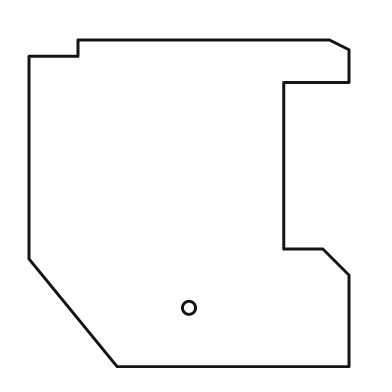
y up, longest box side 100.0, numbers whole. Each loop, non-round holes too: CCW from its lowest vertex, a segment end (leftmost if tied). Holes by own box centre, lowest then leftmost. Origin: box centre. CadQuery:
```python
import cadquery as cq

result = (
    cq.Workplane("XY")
    .moveTo(-22.0, -50.0)
    .lineTo(49.0, -50.0)
    .lineTo(49.0, -22.0)
    .lineTo(41.0, -14.0)
    .lineTo(29.0, -14.0)
    .lineTo(29.0, 37.0)
    .lineTo(49.0, 37.0)
    .lineTo(49.0, 47.0)
    .lineTo(43.0, 50.0)
    .lineTo(-34.0, 50.0)
    .lineTo(-34.0, 45.0)
    .lineTo(-49.0, 45.0)
    .lineTo(-49.0, -17.0)
    .close()
    .moveTo(0.0, -32.0)
    .circle(2.0)
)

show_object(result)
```